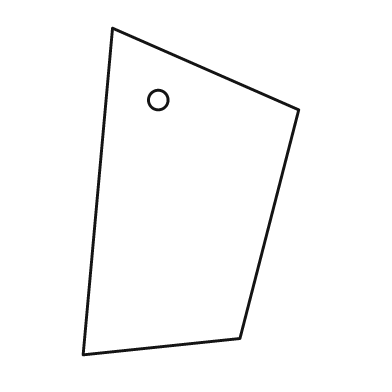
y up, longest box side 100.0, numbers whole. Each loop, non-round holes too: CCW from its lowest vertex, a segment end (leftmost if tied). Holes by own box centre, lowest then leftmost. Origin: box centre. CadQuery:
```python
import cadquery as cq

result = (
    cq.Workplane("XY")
    .moveTo(-33.0, -50.0)
    .lineTo(15.0, -45.0)
    .lineTo(33.0, 25.0)
    .lineTo(-24.0, 50.0)
    .close()
    .moveTo(-10.0, 28.0)
    .circle(3.0)
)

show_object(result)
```